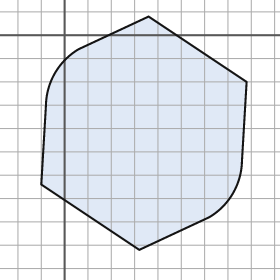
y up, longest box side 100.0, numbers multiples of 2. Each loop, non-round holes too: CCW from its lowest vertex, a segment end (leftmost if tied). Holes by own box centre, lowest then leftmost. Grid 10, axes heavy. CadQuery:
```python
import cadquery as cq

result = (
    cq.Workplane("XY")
    .moveTo(32.0, -92.0)
    .lineTo(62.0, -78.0)
    .threePointArc((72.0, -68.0), (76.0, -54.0))
    .lineTo(78.0, -20.0)
    .lineTo(36.0, 8.0)
    .lineTo(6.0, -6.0)
    .threePointArc((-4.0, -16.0), (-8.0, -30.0))
    .lineTo(-10.0, -64.0)
    .close()
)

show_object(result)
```